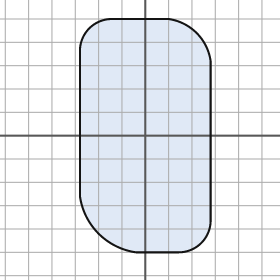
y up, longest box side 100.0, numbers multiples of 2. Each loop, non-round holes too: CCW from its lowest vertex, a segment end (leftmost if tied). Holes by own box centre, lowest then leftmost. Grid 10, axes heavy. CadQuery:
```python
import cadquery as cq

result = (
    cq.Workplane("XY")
    .moveTo(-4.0, -50.0)
    .lineTo(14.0, -50.0)
    .threePointArc((24.0, -46.0), (28.0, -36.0))
    .lineTo(28.0, 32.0)
    .threePointArc((22.0, 44.0), (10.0, 50.0))
    .lineTo(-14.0, 50.0)
    .threePointArc((-24.0, 46.0), (-28.0, 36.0))
    .lineTo(-28.0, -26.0)
    .threePointArc((-20.0, -42.0), (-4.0, -50.0))
    .close()
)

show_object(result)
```